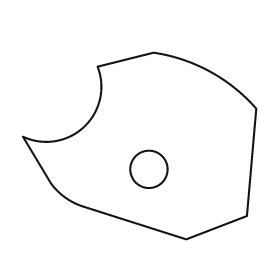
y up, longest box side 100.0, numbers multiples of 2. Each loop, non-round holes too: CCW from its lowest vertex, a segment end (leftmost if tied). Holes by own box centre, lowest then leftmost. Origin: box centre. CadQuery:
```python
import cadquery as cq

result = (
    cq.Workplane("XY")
    .moveTo(20.0, -40.0)
    .lineTo(46.0, -30.0)
    .lineTo(50.0, 16.0)
    .threePointArc((30.0, 32.0), (6.0, 40.0))
    .lineTo(-18.0, 34.0)
    .threePointArc((-24.0, 8.0), (-50.0, 4.0))
    .lineTo(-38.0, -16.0)
    .threePointArc((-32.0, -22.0), (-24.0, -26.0))
    .close()
    .moveTo(4.0, -10.0)
    .circle(8.0)
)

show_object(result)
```